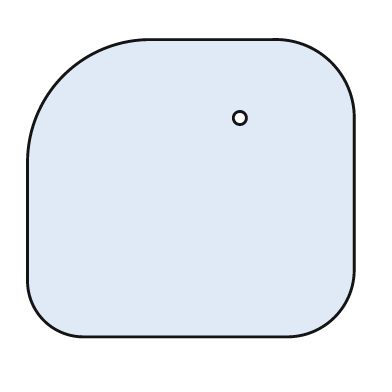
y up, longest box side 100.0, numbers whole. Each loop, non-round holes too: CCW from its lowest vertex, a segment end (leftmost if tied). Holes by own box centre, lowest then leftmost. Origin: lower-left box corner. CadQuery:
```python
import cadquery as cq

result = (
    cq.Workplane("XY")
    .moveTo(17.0, 0.0)
    .lineTo(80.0, 0.0)
    .threePointArc((94.0, 6.0), (100.0, 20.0))
    .lineTo(100.0, 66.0)
    .threePointArc((93.0, 84.0), (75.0, 91.0))
    .lineTo(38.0, 91.0)
    .threePointArc((11.0, 80.0), (0.0, 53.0))
    .lineTo(0.0, 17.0)
    .threePointArc((5.0, 5.0), (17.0, 0.0))
    .close()
    .moveTo(65.0, 67.0)
    .circle(2.0)
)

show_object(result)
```